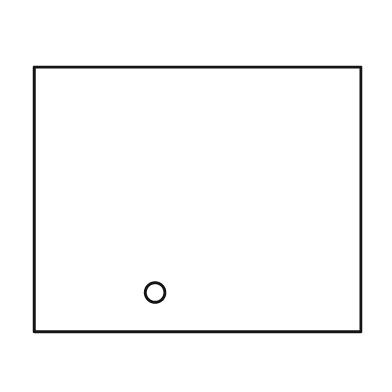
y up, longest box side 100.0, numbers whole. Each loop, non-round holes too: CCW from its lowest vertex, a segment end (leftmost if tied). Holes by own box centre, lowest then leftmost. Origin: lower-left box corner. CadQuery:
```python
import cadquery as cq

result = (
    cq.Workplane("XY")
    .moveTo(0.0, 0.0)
    .lineTo(100.0, 0.0)
    .lineTo(100.0, 81.0)
    .lineTo(0.0, 81.0)
    .close()
    .moveTo(37.0, 12.0)
    .circle(3.0)
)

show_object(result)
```